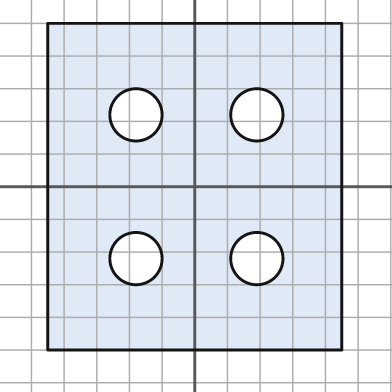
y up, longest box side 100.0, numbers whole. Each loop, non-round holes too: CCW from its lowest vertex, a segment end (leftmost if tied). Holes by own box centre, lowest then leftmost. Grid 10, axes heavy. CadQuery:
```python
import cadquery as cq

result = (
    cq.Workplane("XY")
    .moveTo(-45.0, -50.0)
    .lineTo(45.0, -50.0)
    .lineTo(45.0, 50.0)
    .lineTo(-45.0, 50.0)
    .close()
    .moveTo(-18.0, -22.0)
    .circle(8.0)
    .moveTo(19.0, -22.0)
    .circle(8.0)
    .moveTo(-18.0, 22.0)
    .circle(8.0)
    .moveTo(19.0, 22.0)
    .circle(8.0)
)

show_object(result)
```